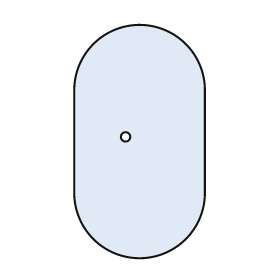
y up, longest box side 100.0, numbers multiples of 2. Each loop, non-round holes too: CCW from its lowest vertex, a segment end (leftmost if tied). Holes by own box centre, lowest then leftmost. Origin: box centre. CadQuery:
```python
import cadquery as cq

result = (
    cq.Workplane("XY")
    .moveTo(-28.0, -22.0)
    .threePointArc((0.0, -50.0), (28.0, -22.0))
    .lineTo(28.0, 22.0)
    .threePointArc((0.0, 50.0), (-28.0, 22.0))
    .close()
    .moveTo(-6.0, 2.0)
    .circle(2.0)
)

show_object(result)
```